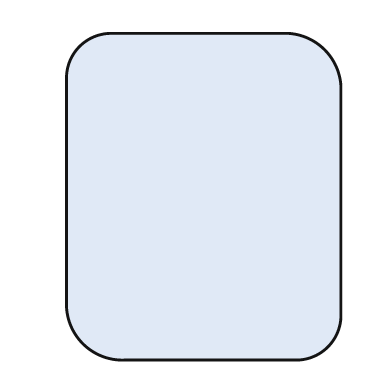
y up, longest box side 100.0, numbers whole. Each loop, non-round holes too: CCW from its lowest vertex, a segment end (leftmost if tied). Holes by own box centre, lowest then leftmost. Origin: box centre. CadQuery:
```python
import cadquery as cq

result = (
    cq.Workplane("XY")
    .moveTo(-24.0, -50.0)
    .lineTo(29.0, -50.0)
    .threePointArc((38.0, -46.0), (42.0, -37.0))
    .lineTo(42.0, 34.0)
    .threePointArc((37.0, 45.0), (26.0, 50.0))
    .lineTo(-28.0, 50.0)
    .threePointArc((-38.0, 46.0), (-42.0, 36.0))
    .lineTo(-42.0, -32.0)
    .threePointArc((-37.0, -45.0), (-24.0, -50.0))
    .close()
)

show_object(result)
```